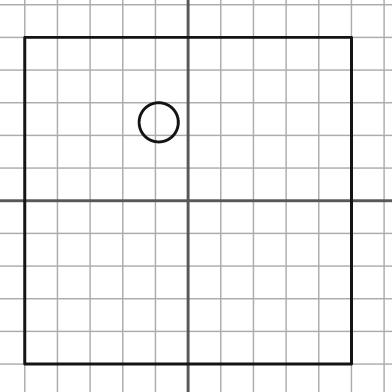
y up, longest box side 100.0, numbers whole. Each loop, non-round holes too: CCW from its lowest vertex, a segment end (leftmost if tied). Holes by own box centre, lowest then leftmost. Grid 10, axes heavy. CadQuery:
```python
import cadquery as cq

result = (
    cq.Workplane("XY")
    .moveTo(-50.0, -50.0)
    .lineTo(50.0, -50.0)
    .lineTo(50.0, 50.0)
    .lineTo(-50.0, 50.0)
    .close()
    .moveTo(-9.0, 24.0)
    .circle(6.0)
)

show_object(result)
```